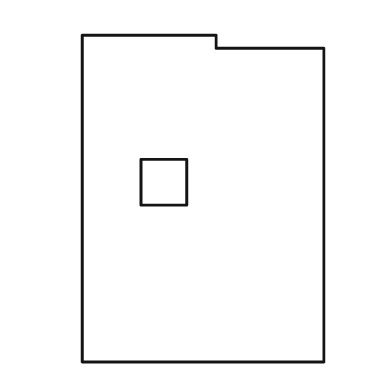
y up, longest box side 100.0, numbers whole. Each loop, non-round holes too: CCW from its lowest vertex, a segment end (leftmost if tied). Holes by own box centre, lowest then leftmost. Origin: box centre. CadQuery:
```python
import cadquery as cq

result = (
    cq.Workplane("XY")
    .moveTo(-37.0, -50.0)
    .lineTo(37.0, -50.0)
    .lineTo(37.0, 46.0)
    .lineTo(4.0, 46.0)
    .lineTo(4.0, 50.0)
    .lineTo(-37.0, 50.0)
    .close()
    .moveTo(-19.0, -2.0)
    .lineTo(-5.0, -2.0)
    .lineTo(-5.0, 12.0)
    .lineTo(-19.0, 12.0)
    .close()
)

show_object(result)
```